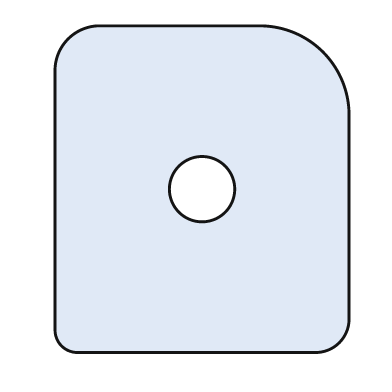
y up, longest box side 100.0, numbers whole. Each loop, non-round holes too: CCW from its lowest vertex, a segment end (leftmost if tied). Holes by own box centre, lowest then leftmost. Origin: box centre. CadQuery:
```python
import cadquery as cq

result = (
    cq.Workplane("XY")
    .moveTo(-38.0, -50.0)
    .lineTo(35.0, -50.0)
    .threePointArc((42.0, -47.0), (45.0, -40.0))
    .lineTo(45.0, 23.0)
    .threePointArc((37.0, 42.0), (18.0, 50.0))
    .lineTo(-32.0, 50.0)
    .threePointArc((-41.0, 46.0), (-45.0, 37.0))
    .lineTo(-45.0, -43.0)
    .threePointArc((-43.0, -48.0), (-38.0, -50.0))
    .close()
    .moveTo(0.0, 0.0)
    .circle(10.0)
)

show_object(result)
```